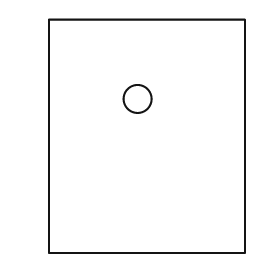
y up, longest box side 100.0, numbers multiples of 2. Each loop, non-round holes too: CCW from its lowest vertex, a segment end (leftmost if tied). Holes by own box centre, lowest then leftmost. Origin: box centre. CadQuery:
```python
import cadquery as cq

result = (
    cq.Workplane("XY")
    .moveTo(-42.0, -50.0)
    .lineTo(42.0, -50.0)
    .lineTo(42.0, 50.0)
    .lineTo(-42.0, 50.0)
    .close()
    .moveTo(-4.0, 16.0)
    .circle(6.0)
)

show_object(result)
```